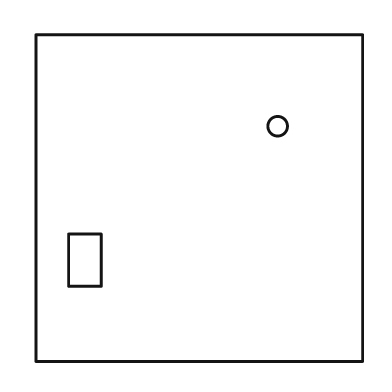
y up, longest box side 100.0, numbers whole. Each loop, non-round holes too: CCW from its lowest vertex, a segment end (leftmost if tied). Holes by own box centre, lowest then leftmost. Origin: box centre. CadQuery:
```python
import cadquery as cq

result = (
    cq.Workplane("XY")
    .moveTo(-50.0, -50.0)
    .lineTo(50.0, -50.0)
    .lineTo(50.0, 50.0)
    .lineTo(-50.0, 50.0)
    .close()
    .moveTo(-40.0, -27.0)
    .lineTo(-30.0, -27.0)
    .lineTo(-30.0, -11.0)
    .lineTo(-40.0, -11.0)
    .close()
    .moveTo(24.0, 22.0)
    .circle(3.0)
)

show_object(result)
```